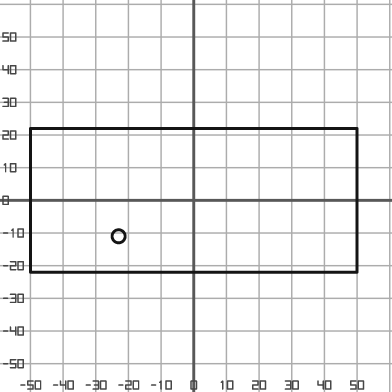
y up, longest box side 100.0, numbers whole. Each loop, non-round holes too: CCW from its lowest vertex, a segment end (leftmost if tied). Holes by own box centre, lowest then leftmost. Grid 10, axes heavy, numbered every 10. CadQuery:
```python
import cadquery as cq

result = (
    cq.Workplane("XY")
    .moveTo(-50.0, -22.0)
    .lineTo(50.0, -22.0)
    .lineTo(50.0, 22.0)
    .lineTo(-50.0, 22.0)
    .close()
    .moveTo(-23.0, -11.0)
    .circle(2.0)
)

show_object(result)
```